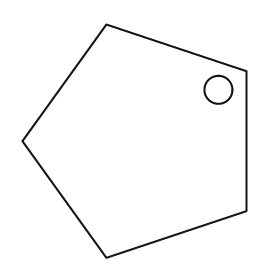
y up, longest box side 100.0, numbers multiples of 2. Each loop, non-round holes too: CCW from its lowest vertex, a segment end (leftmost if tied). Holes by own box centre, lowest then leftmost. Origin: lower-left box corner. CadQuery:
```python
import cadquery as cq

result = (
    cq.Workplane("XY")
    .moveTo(36.0, 0.0)
    .lineTo(96.0, 20.0)
    .lineTo(96.0, 80.0)
    .lineTo(36.0, 100.0)
    .lineTo(0.0, 50.0)
    .close()
    .moveTo(84.0, 72.0)
    .circle(6.0)
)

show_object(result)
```